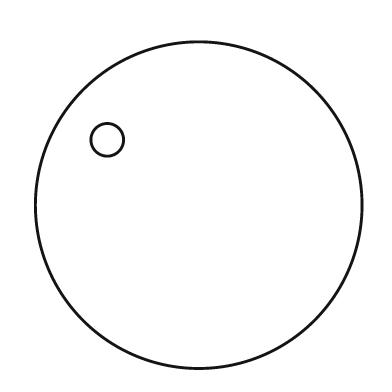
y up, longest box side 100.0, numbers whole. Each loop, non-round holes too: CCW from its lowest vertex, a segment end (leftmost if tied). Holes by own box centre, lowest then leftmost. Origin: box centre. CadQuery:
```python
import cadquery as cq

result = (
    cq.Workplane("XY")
    .moveTo(0.0, 0.0)
    .circle(50.0)
    .moveTo(-28.0, 20.0)
    .circle(5.0)
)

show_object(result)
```